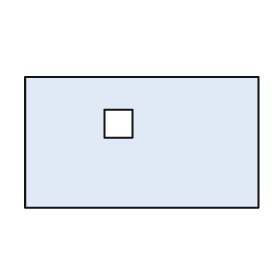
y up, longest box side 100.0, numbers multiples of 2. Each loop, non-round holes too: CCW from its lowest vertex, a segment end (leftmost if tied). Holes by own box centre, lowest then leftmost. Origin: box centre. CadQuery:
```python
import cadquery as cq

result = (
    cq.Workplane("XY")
    .moveTo(-50.0, -28.0)
    .lineTo(50.0, -28.0)
    .lineTo(50.0, 28.0)
    .lineTo(-50.0, 28.0)
    .close()
    .moveTo(-16.0, 2.0)
    .lineTo(-4.0, 2.0)
    .lineTo(-4.0, 14.0)
    .lineTo(-16.0, 14.0)
    .close()
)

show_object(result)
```